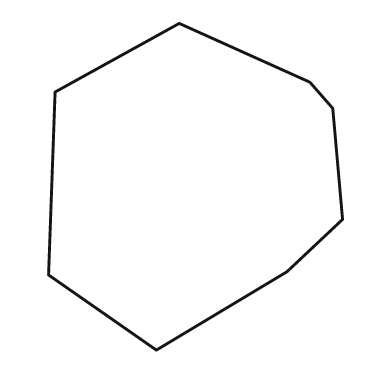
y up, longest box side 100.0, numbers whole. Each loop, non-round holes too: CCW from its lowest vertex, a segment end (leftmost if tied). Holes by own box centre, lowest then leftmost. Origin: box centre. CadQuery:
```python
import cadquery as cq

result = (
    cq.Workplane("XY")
    .moveTo(-12.0, -50.0)
    .lineTo(28.0, -26.0)
    .lineTo(45.0, -10.0)
    .lineTo(42.0, 24.0)
    .lineTo(35.0, 32.0)
    .lineTo(-5.0, 50.0)
    .lineTo(-43.0, 29.0)
    .lineTo(-45.0, -27.0)
    .close()
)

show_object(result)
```